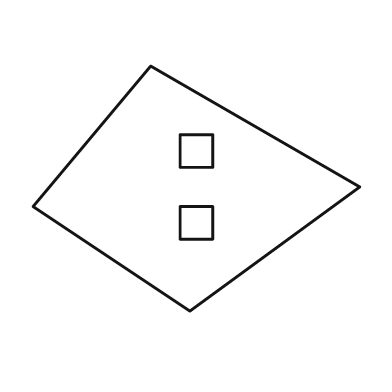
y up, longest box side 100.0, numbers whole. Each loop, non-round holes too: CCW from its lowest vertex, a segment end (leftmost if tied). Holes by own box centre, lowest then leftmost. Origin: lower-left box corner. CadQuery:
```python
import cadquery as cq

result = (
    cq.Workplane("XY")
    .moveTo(48.0, 0.0)
    .lineTo(100.0, 38.0)
    .lineTo(36.0, 75.0)
    .lineTo(0.0, 32.0)
    .close()
    .moveTo(45.0, 22.0)
    .lineTo(55.0, 22.0)
    .lineTo(55.0, 32.0)
    .lineTo(45.0, 32.0)
    .close()
    .moveTo(45.0, 44.0)
    .lineTo(55.0, 44.0)
    .lineTo(55.0, 54.0)
    .lineTo(45.0, 54.0)
    .close()
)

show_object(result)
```